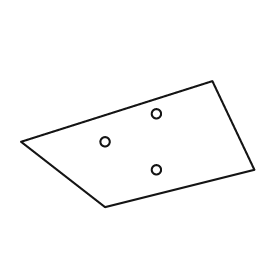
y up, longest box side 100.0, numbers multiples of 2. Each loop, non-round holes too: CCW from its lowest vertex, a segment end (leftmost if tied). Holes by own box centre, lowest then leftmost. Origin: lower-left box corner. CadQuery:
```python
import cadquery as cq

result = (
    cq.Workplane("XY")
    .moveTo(36.0, 0.0)
    .lineTo(100.0, 16.0)
    .lineTo(82.0, 54.0)
    .lineTo(0.0, 28.0)
    .close()
    .moveTo(58.0, 16.0)
    .circle(2.0)
    .moveTo(36.0, 28.0)
    .circle(2.0)
    .moveTo(58.0, 40.0)
    .circle(2.0)
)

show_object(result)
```